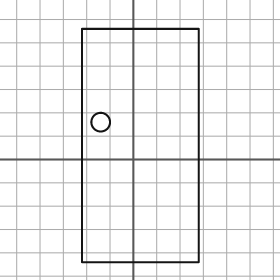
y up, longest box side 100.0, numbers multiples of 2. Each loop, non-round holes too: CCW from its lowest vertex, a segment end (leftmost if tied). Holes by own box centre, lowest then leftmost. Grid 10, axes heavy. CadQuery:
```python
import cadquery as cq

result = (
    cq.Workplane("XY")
    .moveTo(-22.0, -44.0)
    .lineTo(28.0, -44.0)
    .lineTo(28.0, 56.0)
    .lineTo(-22.0, 56.0)
    .close()
    .moveTo(-14.0, 16.0)
    .circle(4.0)
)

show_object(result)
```